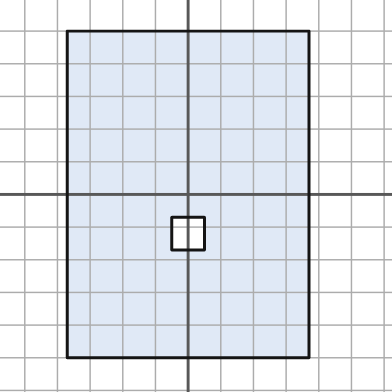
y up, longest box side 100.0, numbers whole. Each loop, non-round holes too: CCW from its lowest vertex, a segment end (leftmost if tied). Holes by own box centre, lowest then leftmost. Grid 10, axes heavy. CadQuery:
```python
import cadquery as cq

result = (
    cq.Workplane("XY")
    .moveTo(-37.0, -50.0)
    .lineTo(37.0, -50.0)
    .lineTo(37.0, 50.0)
    .lineTo(-37.0, 50.0)
    .close()
    .moveTo(-5.0, -17.0)
    .lineTo(5.0, -17.0)
    .lineTo(5.0, -7.0)
    .lineTo(-5.0, -7.0)
    .close()
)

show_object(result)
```